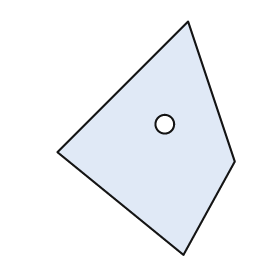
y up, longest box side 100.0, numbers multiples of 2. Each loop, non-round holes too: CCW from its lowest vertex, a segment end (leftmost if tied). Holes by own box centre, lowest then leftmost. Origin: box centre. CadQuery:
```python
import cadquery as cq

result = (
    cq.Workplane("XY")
    .moveTo(16.0, -50.0)
    .lineTo(38.0, -10.0)
    .lineTo(18.0, 50.0)
    .lineTo(-38.0, -6.0)
    .close()
    .moveTo(8.0, 6.0)
    .circle(4.0)
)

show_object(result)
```